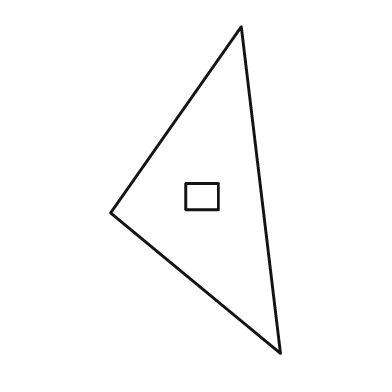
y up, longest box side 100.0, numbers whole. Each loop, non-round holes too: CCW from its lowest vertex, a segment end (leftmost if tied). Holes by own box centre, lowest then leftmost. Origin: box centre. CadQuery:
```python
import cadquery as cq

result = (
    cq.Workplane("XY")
    .moveTo(26.0, -50.0)
    .lineTo(14.0, 50.0)
    .lineTo(-26.0, -7.0)
    .close()
    .moveTo(-3.0, -6.0)
    .lineTo(7.0, -6.0)
    .lineTo(7.0, 2.0)
    .lineTo(-3.0, 2.0)
    .close()
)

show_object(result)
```